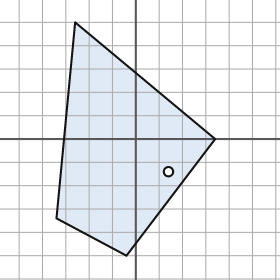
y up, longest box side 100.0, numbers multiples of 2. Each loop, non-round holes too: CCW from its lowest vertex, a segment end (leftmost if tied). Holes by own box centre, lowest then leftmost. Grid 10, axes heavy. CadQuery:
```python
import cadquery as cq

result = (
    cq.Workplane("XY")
    .moveTo(-4.0, -50.0)
    .lineTo(34.0, 0.0)
    .lineTo(-26.0, 50.0)
    .lineTo(-34.0, -34.0)
    .close()
    .moveTo(14.0, -14.0)
    .circle(2.0)
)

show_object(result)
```